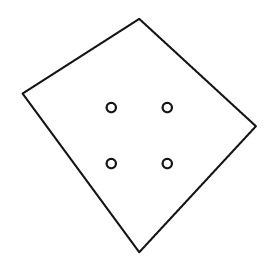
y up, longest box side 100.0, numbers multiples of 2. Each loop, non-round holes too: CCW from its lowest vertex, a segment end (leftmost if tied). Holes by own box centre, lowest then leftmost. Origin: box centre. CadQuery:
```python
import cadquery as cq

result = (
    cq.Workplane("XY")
    .moveTo(0.0, -50.0)
    .lineTo(50.0, 4.0)
    .lineTo(0.0, 50.0)
    .lineTo(-50.0, 18.0)
    .close()
    .moveTo(-12.0, -12.0)
    .circle(2.0)
    .moveTo(12.0, -12.0)
    .circle(2.0)
    .moveTo(-12.0, 12.0)
    .circle(2.0)
    .moveTo(12.0, 12.0)
    .circle(2.0)
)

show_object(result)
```